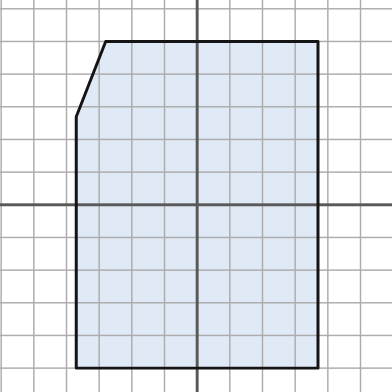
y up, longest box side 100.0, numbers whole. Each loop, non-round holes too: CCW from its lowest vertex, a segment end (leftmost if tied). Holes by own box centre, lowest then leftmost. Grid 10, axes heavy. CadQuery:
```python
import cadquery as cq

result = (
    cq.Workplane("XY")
    .moveTo(-37.0, -50.0)
    .lineTo(37.0, -50.0)
    .lineTo(37.0, 50.0)
    .lineTo(-28.0, 50.0)
    .lineTo(-37.0, 27.0)
    .close()
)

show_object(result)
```